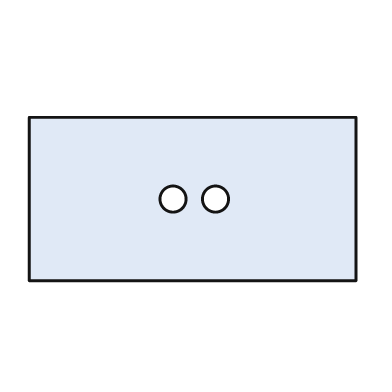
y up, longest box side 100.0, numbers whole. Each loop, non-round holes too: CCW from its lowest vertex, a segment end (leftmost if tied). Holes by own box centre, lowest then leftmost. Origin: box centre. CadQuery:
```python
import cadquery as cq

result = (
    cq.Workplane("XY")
    .moveTo(-50.0, -25.0)
    .lineTo(50.0, -25.0)
    .lineTo(50.0, 25.0)
    .lineTo(-50.0, 25.0)
    .close()
    .moveTo(-6.0, 0.0)
    .circle(4.0)
    .moveTo(7.0, 0.0)
    .circle(4.0)
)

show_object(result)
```